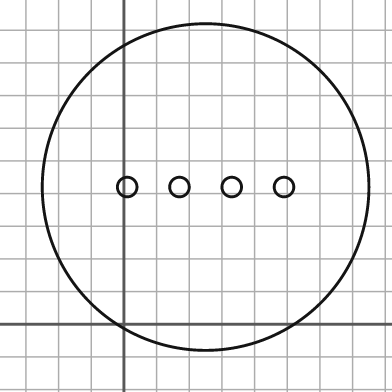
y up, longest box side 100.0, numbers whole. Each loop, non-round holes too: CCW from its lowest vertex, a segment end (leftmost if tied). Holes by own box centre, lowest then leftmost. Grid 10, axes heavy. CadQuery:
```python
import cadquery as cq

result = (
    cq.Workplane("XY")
    .moveTo(25.0, 42.0)
    .circle(50.0)
    .moveTo(1.0, 42.0)
    .circle(3.0)
    .moveTo(17.0, 42.0)
    .circle(3.0)
    .moveTo(33.0, 42.0)
    .circle(3.0)
    .moveTo(49.0, 42.0)
    .circle(3.0)
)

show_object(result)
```